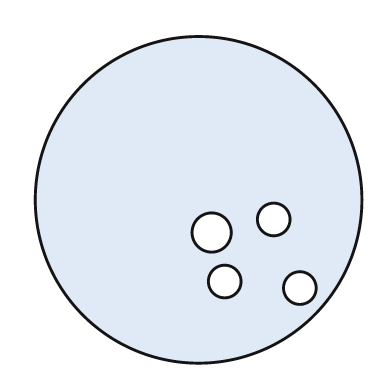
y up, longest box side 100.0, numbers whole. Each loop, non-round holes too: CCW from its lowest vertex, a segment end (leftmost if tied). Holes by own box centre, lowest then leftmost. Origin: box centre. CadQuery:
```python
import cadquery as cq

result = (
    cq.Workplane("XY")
    .moveTo(0.0, 0.0)
    .circle(50.0)
    .moveTo(31.0, -27.0)
    .circle(5.0)
    .moveTo(8.0, -25.0)
    .circle(5.0)
    .moveTo(4.0, -10.0)
    .circle(6.0)
    .moveTo(23.0, -6.0)
    .circle(5.0)
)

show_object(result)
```